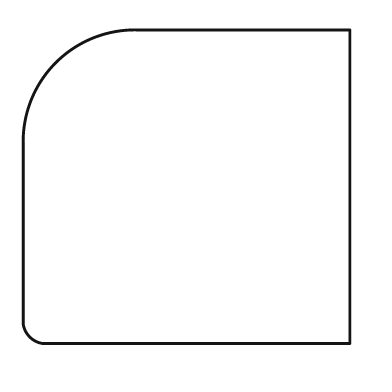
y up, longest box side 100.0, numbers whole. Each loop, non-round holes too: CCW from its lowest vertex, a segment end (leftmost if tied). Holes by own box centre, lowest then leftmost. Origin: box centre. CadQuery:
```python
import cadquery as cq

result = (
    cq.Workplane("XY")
    .moveTo(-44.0, -48.0)
    .lineTo(50.0, -48.0)
    .lineTo(50.0, 48.0)
    .lineTo(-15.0, 48.0)
    .threePointArc((-40.0, 38.0), (-50.0, 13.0))
    .lineTo(-50.0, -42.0)
    .threePointArc((-48.0, -46.0), (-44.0, -48.0))
    .close()
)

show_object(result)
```